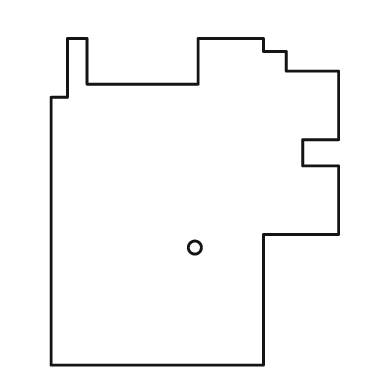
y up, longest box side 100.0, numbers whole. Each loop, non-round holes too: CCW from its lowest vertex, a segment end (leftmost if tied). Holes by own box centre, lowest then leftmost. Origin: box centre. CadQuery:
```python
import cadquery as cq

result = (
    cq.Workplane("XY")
    .moveTo(-44.0, -50.0)
    .lineTo(21.0, -50.0)
    .lineTo(21.0, -10.0)
    .lineTo(44.0, -10.0)
    .lineTo(44.0, 11.0)
    .lineTo(33.0, 11.0)
    .lineTo(33.0, 19.0)
    .lineTo(44.0, 19.0)
    .lineTo(44.0, 40.0)
    .lineTo(28.0, 40.0)
    .lineTo(28.0, 46.0)
    .lineTo(21.0, 46.0)
    .lineTo(21.0, 50.0)
    .lineTo(1.0, 50.0)
    .lineTo(1.0, 36.0)
    .lineTo(-33.0, 36.0)
    .lineTo(-33.0, 50.0)
    .lineTo(-39.0, 50.0)
    .lineTo(-39.0, 32.0)
    .lineTo(-44.0, 32.0)
    .close()
    .moveTo(0.0, -14.0)
    .circle(2.0)
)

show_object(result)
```